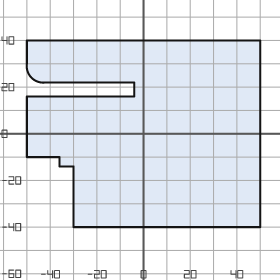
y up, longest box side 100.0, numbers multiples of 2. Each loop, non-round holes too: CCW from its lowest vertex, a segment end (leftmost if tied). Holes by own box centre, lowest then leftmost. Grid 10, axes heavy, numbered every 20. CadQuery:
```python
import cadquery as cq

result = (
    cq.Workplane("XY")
    .moveTo(-30.0, -40.0)
    .lineTo(50.0, -40.0)
    .lineTo(50.0, 40.0)
    .lineTo(-50.0, 40.0)
    .lineTo(-50.0, 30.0)
    .threePointArc((-48.0, 24.0), (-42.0, 22.0))
    .lineTo(-4.0, 22.0)
    .lineTo(-4.0, 16.0)
    .lineTo(-50.0, 16.0)
    .lineTo(-50.0, -10.0)
    .lineTo(-36.0, -10.0)
    .lineTo(-36.0, -14.0)
    .lineTo(-30.0, -14.0)
    .close()
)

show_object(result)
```